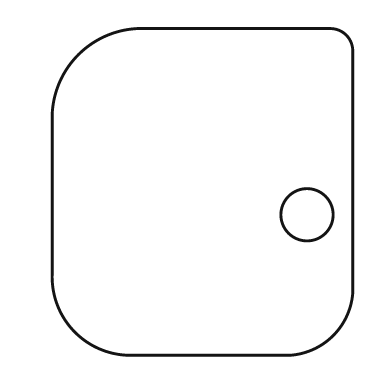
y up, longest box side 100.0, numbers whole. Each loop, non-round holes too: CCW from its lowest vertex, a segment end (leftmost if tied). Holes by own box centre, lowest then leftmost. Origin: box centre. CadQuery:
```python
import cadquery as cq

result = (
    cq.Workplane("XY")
    .moveTo(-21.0, -50.0)
    .lineTo(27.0, -50.0)
    .threePointArc((40.0, -44.0), (46.0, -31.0))
    .lineTo(46.0, 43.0)
    .threePointArc((44.0, 48.0), (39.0, 50.0))
    .lineTo(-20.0, 50.0)
    .threePointArc((-38.0, 42.0), (-46.0, 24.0))
    .lineTo(-46.0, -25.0)
    .threePointArc((-39.0, -43.0), (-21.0, -50.0))
    .close()
    .moveTo(32.0, -7.0)
    .circle(8.0)
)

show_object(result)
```